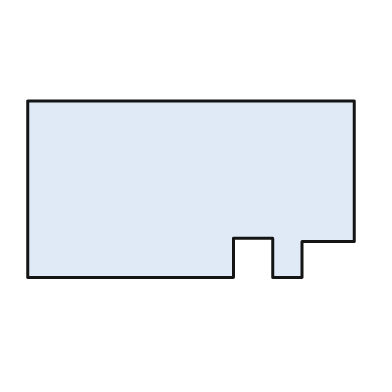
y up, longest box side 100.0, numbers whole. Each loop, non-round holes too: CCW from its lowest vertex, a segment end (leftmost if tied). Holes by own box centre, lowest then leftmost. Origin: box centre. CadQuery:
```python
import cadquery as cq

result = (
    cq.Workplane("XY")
    .moveTo(-50.0, -27.0)
    .lineTo(13.0, -27.0)
    .lineTo(13.0, -15.0)
    .lineTo(25.0, -15.0)
    .lineTo(25.0, -27.0)
    .lineTo(34.0, -27.0)
    .lineTo(34.0, -16.0)
    .lineTo(50.0, -16.0)
    .lineTo(50.0, 27.0)
    .lineTo(-50.0, 27.0)
    .close()
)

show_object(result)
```